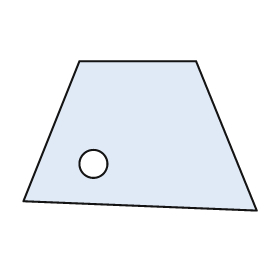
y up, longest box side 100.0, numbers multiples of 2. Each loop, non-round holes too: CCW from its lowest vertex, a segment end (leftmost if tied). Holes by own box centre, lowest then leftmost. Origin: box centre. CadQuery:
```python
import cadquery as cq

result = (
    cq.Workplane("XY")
    .moveTo(50.0, -32.0)
    .lineTo(24.0, 32.0)
    .lineTo(-26.0, 32.0)
    .lineTo(-50.0, -28.0)
    .close()
    .moveTo(-20.0, -12.0)
    .circle(6.0)
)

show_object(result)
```